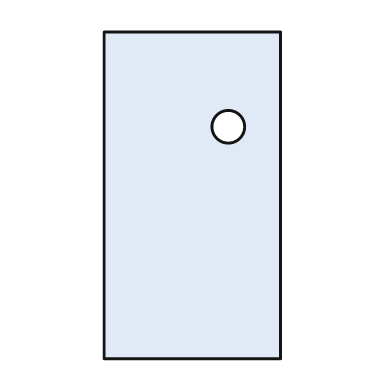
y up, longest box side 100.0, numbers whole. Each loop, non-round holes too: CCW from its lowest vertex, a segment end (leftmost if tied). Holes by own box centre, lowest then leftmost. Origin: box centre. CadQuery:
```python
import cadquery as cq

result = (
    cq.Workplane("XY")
    .moveTo(-27.0, -50.0)
    .lineTo(27.0, -50.0)
    .lineTo(27.0, 50.0)
    .lineTo(-27.0, 50.0)
    .close()
    .moveTo(11.0, 21.0)
    .circle(5.0)
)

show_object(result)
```